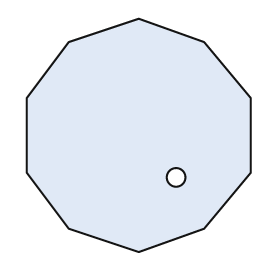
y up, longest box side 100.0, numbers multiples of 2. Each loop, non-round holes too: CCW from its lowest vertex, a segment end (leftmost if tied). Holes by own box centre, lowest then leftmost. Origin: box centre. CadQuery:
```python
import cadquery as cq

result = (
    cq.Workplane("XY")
    .moveTo(0.0, -50.0)
    .lineTo(28.0, -40.0)
    .lineTo(48.0, -16.0)
    .lineTo(48.0, 16.0)
    .lineTo(28.0, 40.0)
    .lineTo(0.0, 50.0)
    .lineTo(-30.0, 40.0)
    .lineTo(-48.0, 16.0)
    .lineTo(-48.0, -16.0)
    .lineTo(-30.0, -40.0)
    .close()
    .moveTo(16.0, -18.0)
    .circle(4.0)
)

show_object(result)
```